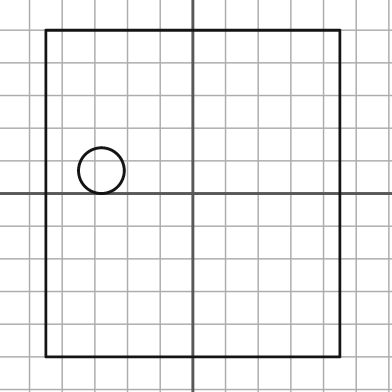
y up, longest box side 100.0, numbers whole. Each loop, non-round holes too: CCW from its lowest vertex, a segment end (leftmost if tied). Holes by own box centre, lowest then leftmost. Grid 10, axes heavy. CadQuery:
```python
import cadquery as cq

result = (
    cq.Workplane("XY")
    .moveTo(-45.0, -50.0)
    .lineTo(45.0, -50.0)
    .lineTo(45.0, 50.0)
    .lineTo(-45.0, 50.0)
    .close()
    .moveTo(-28.0, 7.0)
    .circle(7.0)
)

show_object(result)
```